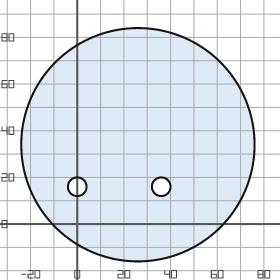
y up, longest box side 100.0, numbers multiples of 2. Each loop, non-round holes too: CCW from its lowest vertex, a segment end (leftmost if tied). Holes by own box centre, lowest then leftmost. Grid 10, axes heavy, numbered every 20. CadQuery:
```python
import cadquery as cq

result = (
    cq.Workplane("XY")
    .moveTo(26.0, 34.0)
    .circle(50.0)
    .moveTo(0.0, 16.0)
    .circle(4.0)
    .moveTo(36.0, 16.0)
    .circle(4.0)
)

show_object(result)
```